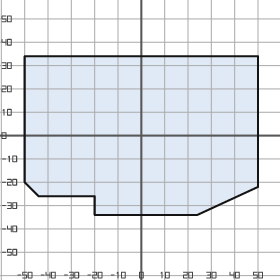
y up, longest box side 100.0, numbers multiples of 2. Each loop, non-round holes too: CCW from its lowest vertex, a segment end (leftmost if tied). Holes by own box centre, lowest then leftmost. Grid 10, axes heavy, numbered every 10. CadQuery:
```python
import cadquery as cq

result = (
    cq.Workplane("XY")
    .moveTo(-20.0, -34.0)
    .lineTo(24.0, -34.0)
    .lineTo(50.0, -22.0)
    .lineTo(50.0, 34.0)
    .lineTo(-50.0, 34.0)
    .lineTo(-50.0, -20.0)
    .lineTo(-44.0, -26.0)
    .lineTo(-20.0, -26.0)
    .close()
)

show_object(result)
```